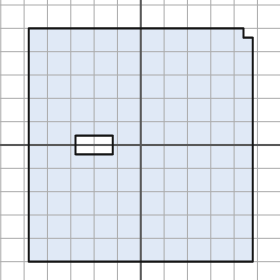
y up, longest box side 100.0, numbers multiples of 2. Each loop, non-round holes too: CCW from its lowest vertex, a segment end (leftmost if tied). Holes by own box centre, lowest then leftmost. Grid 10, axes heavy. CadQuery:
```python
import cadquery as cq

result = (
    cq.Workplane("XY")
    .moveTo(-48.0, -50.0)
    .lineTo(48.0, -50.0)
    .lineTo(48.0, 46.0)
    .lineTo(44.0, 46.0)
    .lineTo(44.0, 50.0)
    .lineTo(-48.0, 50.0)
    .close()
    .moveTo(-28.0, -4.0)
    .lineTo(-12.0, -4.0)
    .lineTo(-12.0, 4.0)
    .lineTo(-28.0, 4.0)
    .close()
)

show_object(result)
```